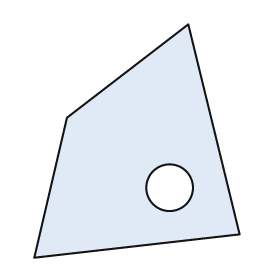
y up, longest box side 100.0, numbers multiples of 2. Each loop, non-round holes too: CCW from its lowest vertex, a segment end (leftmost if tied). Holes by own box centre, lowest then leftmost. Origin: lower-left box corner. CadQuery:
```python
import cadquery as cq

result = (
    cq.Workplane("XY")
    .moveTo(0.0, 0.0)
    .lineTo(88.0, 10.0)
    .lineTo(66.0, 100.0)
    .lineTo(14.0, 60.0)
    .close()
    .moveTo(58.0, 30.0)
    .circle(10.0)
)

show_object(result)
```